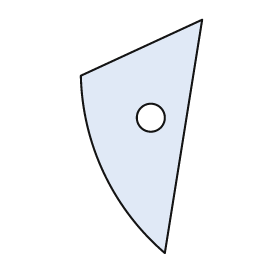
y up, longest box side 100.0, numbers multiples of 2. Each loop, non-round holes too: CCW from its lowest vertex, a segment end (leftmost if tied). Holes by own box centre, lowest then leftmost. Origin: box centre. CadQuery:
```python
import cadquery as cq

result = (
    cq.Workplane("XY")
    .moveTo(10.0, -50.0)
    .lineTo(26.0, 50.0)
    .lineTo(-26.0, 26.0)
    .threePointArc((-16.0, -16.0), (10.0, -50.0))
    .close()
    .moveTo(4.0, 8.0)
    .circle(6.0)
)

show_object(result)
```